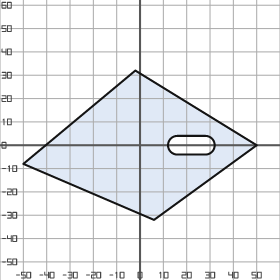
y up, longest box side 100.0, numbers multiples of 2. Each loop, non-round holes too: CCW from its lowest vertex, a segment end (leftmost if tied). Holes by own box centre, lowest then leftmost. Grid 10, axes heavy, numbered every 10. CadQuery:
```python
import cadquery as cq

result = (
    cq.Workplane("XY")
    .moveTo(6.0, -32.0)
    .lineTo(50.0, 0.0)
    .lineTo(-2.0, 32.0)
    .lineTo(-50.0, -8.0)
    .close()
    .moveTo(16.0, -4.0)
    .lineTo(28.0, -4.0)
    .threePointArc((32.0, 0.0), (28.0, 4.0))
    .lineTo(16.0, 4.0)
    .threePointArc((12.0, 0.0), (16.0, -4.0))
    .close()
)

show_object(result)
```